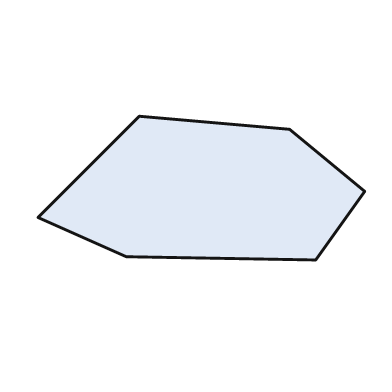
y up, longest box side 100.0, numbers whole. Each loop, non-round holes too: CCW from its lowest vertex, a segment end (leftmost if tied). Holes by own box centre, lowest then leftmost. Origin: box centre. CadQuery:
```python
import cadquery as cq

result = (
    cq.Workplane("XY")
    .moveTo(35.0, -22.0)
    .lineTo(50.0, -1.0)
    .lineTo(27.0, 18.0)
    .lineTo(-19.0, 22.0)
    .lineTo(-50.0, -9.0)
    .lineTo(-23.0, -21.0)
    .close()
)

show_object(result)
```